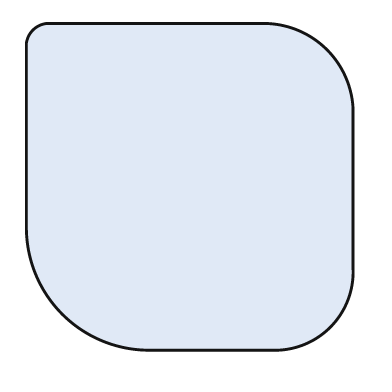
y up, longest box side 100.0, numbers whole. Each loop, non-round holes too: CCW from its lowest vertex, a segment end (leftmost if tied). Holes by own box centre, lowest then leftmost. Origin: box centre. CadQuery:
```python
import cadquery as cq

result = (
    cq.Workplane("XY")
    .moveTo(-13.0, -50.0)
    .lineTo(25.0, -50.0)
    .threePointArc((43.0, -43.0), (50.0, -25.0))
    .lineTo(50.0, 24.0)
    .threePointArc((42.0, 42.0), (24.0, 50.0))
    .lineTo(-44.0, 50.0)
    .threePointArc((-48.0, 48.0), (-50.0, 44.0))
    .lineTo(-50.0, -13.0)
    .threePointArc((-39.0, -39.0), (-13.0, -50.0))
    .close()
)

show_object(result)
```